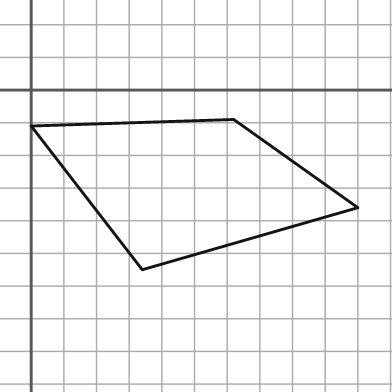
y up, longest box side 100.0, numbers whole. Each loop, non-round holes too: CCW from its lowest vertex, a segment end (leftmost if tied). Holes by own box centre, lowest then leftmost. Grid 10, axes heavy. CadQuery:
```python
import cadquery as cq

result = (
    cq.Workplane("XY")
    .moveTo(34.0, -55.0)
    .lineTo(100.0, -36.0)
    .lineTo(62.0, -9.0)
    .lineTo(0.0, -11.0)
    .close()
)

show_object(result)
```